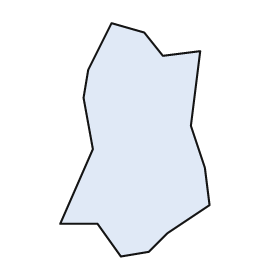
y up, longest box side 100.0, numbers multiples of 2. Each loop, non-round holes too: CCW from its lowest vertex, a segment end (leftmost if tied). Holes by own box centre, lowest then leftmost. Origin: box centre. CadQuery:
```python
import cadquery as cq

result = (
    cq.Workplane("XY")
    .moveTo(-6.0, -50.0)
    .lineTo(6.0, -48.0)
    .lineTo(14.0, -40.0)
    .lineTo(32.0, -28.0)
    .lineTo(30.0, -12.0)
    .lineTo(24.0, 6.0)
    .lineTo(28.0, 38.0)
    .lineTo(12.0, 36.0)
    .lineTo(4.0, 46.0)
    .lineTo(-10.0, 50.0)
    .lineTo(-20.0, 30.0)
    .lineTo(-22.0, 18.0)
    .lineTo(-18.0, -4.0)
    .lineTo(-32.0, -36.0)
    .lineTo(-16.0, -36.0)
    .close()
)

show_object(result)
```